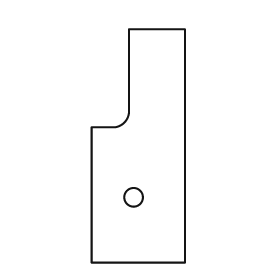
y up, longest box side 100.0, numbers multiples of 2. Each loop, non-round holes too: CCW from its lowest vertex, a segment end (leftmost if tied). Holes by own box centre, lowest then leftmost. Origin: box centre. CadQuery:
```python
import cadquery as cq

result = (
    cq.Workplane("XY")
    .moveTo(-20.0, -50.0)
    .lineTo(20.0, -50.0)
    .lineTo(20.0, 50.0)
    .lineTo(-4.0, 50.0)
    .lineTo(-4.0, 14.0)
    .threePointArc((-6.0, 10.0), (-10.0, 8.0))
    .lineTo(-20.0, 8.0)
    .close()
    .moveTo(-2.0, -22.0)
    .circle(4.0)
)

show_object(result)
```